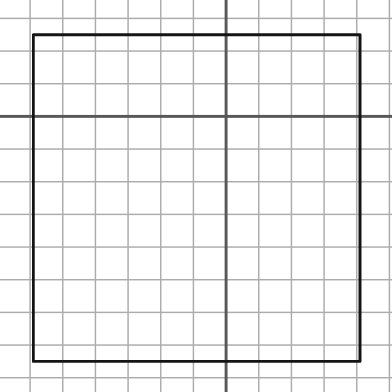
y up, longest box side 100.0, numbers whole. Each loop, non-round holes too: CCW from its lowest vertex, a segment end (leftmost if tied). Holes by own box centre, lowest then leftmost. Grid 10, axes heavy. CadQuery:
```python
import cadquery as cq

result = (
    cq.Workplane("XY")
    .moveTo(-59.0, -75.0)
    .lineTo(41.0, -75.0)
    .lineTo(41.0, 25.0)
    .lineTo(-59.0, 25.0)
    .close()
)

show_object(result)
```